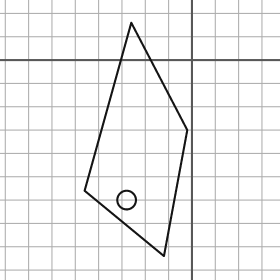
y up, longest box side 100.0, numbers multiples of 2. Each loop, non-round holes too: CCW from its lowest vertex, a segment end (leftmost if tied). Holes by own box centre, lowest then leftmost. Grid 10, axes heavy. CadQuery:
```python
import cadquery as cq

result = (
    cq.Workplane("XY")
    .moveTo(-12.0, -84.0)
    .lineTo(-2.0, -30.0)
    .lineTo(-26.0, 16.0)
    .lineTo(-46.0, -56.0)
    .close()
    .moveTo(-28.0, -60.0)
    .circle(4.0)
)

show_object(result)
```